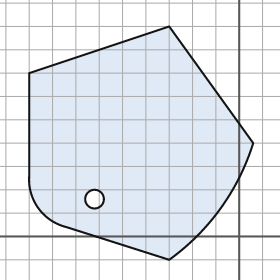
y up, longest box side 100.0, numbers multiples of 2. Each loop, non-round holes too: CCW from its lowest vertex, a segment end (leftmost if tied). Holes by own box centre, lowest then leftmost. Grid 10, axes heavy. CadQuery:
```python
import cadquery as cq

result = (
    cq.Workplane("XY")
    .moveTo(-30.0, -10.0)
    .threePointArc((-8.0, 12.0), (6.0, 40.0))
    .lineTo(-30.0, 90.0)
    .lineTo(-90.0, 70.0)
    .lineTo(-90.0, 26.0)
    .threePointArc((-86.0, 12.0), (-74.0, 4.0))
    .close()
    .moveTo(-62.0, 16.0)
    .circle(4.0)
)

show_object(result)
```